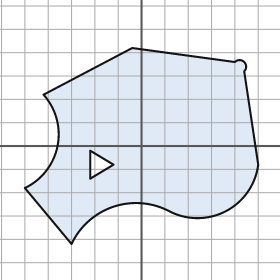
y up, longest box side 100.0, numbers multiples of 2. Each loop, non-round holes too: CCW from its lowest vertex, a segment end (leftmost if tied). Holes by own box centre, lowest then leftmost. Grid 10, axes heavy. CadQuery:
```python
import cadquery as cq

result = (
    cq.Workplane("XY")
    .moveTo(-30.0, -42.0)
    .threePointArc((-12.0, -26.0), (12.0, -28.0))
    .threePointArc((36.0, -28.0), (50.0, -8.0))
    .lineTo(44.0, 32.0)
    .threePointArc((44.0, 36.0), (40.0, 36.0))
    .lineTo(-4.0, 42.0)
    .lineTo(-42.0, 22.0)
    .threePointArc((-36.0, 0.0), (-50.0, -18.0))
    .close()
    .moveTo(-22.0, -14.0)
    .lineTo(-12.0, -8.0)
    .lineTo(-22.0, -2.0)
    .close()
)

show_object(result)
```